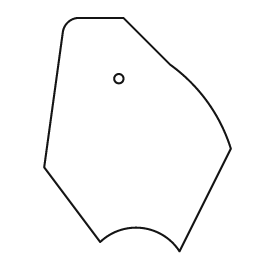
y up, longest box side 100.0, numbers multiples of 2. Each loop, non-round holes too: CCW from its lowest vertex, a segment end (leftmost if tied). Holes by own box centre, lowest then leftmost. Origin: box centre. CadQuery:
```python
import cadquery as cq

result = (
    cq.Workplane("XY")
    .moveTo(18.0, -50.0)
    .lineTo(40.0, -6.0)
    .threePointArc((30.0, 14.0), (14.0, 30.0))
    .lineTo(-6.0, 50.0)
    .lineTo(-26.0, 50.0)
    .threePointArc((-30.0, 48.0), (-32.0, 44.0))
    .lineTo(-40.0, -14.0)
    .lineTo(-16.0, -46.0)
    .threePointArc((2.0, -40.0), (18.0, -50.0))
    .close()
    .moveTo(-8.0, 24.0)
    .circle(2.0)
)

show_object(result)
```